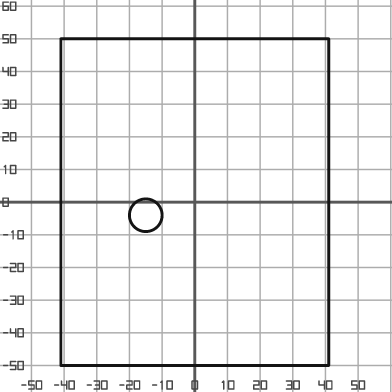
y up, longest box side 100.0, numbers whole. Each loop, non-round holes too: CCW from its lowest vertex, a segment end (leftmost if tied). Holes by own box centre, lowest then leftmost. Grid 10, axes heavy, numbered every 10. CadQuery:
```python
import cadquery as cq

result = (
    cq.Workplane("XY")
    .moveTo(-41.0, -50.0)
    .lineTo(41.0, -50.0)
    .lineTo(41.0, 50.0)
    .lineTo(-41.0, 50.0)
    .close()
    .moveTo(-15.0, -4.0)
    .circle(5.0)
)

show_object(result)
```